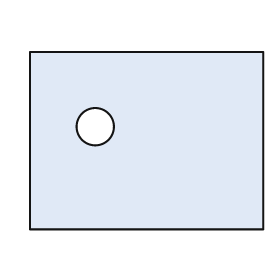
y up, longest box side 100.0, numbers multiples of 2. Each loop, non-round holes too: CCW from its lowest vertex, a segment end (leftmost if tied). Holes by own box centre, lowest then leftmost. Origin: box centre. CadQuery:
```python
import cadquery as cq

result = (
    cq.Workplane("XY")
    .moveTo(-50.0, -38.0)
    .lineTo(50.0, -38.0)
    .lineTo(50.0, 38.0)
    .lineTo(-50.0, 38.0)
    .close()
    .moveTo(-22.0, 6.0)
    .circle(8.0)
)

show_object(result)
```